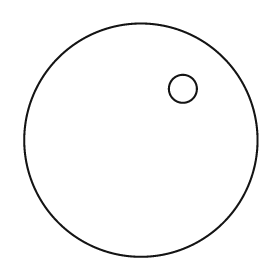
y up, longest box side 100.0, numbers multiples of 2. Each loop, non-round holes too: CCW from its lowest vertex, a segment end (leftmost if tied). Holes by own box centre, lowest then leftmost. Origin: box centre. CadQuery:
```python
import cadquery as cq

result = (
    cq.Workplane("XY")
    .moveTo(0.0, 0.0)
    .circle(50.0)
    .moveTo(18.0, 22.0)
    .circle(6.0)
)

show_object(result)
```